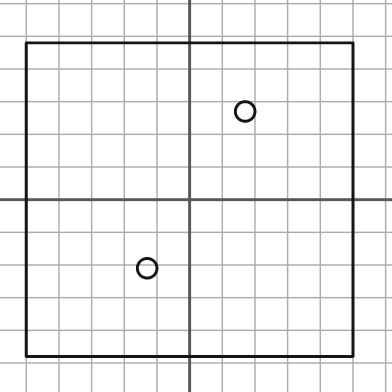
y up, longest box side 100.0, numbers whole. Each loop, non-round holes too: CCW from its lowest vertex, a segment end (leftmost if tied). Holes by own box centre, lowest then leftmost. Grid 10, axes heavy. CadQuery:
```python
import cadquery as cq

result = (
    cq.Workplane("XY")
    .moveTo(-50.0, -48.0)
    .lineTo(50.0, -48.0)
    .lineTo(50.0, 48.0)
    .lineTo(-50.0, 48.0)
    .close()
    .moveTo(-13.0, -21.0)
    .circle(3.0)
    .moveTo(17.0, 27.0)
    .circle(3.0)
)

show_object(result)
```